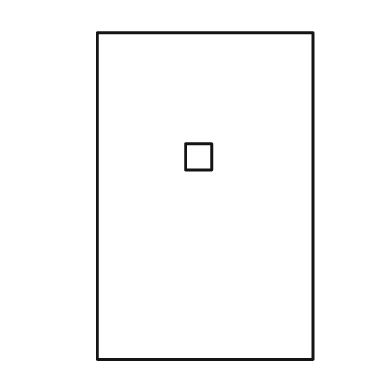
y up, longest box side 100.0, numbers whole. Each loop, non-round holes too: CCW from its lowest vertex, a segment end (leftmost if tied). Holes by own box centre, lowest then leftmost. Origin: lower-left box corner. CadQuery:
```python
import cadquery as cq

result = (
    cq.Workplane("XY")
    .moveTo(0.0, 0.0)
    .lineTo(66.0, 0.0)
    .lineTo(66.0, 100.0)
    .lineTo(0.0, 100.0)
    .close()
    .moveTo(27.0, 58.0)
    .lineTo(35.0, 58.0)
    .lineTo(35.0, 66.0)
    .lineTo(27.0, 66.0)
    .close()
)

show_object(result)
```